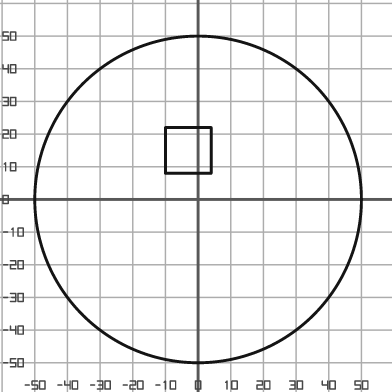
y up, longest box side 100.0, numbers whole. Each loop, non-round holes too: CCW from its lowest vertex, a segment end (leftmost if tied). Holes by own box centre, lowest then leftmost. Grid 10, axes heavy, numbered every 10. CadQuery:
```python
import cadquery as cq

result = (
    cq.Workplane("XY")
    .moveTo(0.0, 0.0)
    .circle(50.0)
    .moveTo(-10.0, 8.0)
    .lineTo(4.0, 8.0)
    .lineTo(4.0, 22.0)
    .lineTo(-10.0, 22.0)
    .close()
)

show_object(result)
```